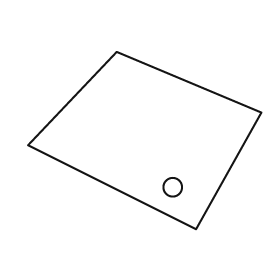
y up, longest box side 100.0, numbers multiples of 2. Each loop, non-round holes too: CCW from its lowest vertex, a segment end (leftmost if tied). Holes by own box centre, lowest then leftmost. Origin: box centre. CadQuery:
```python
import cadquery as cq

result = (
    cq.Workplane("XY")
    .moveTo(22.0, -38.0)
    .lineTo(50.0, 12.0)
    .lineTo(-12.0, 38.0)
    .lineTo(-50.0, -2.0)
    .close()
    .moveTo(12.0, -20.0)
    .circle(4.0)
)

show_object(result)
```